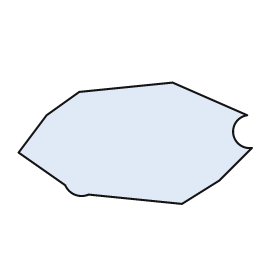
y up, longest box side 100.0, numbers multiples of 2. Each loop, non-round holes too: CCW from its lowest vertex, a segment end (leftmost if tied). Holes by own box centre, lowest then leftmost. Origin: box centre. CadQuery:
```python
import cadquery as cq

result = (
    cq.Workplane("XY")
    .moveTo(20.0, -26.0)
    .lineTo(36.0, -16.0)
    .lineTo(50.0, -2.0)
    .threePointArc((42.0, 4.0), (48.0, 12.0))
    .lineTo(16.0, 26.0)
    .lineTo(-24.0, 22.0)
    .lineTo(-38.0, 12.0)
    .lineTo(-50.0, -4.0)
    .lineTo(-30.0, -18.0)
    .threePointArc((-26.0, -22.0), (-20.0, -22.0))
    .close()
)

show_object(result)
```